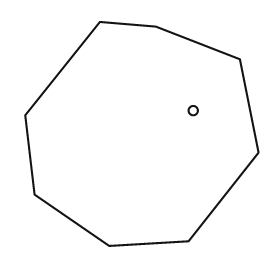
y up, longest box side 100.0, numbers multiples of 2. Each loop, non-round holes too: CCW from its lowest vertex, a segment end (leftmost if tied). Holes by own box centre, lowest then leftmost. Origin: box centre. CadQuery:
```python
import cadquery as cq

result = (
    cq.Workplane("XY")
    .moveTo(-14.0, -48.0)
    .lineTo(20.0, -46.0)
    .lineTo(50.0, -8.0)
    .lineTo(42.0, 32.0)
    .lineTo(6.0, 46.0)
    .lineTo(-18.0, 48.0)
    .lineTo(-50.0, 8.0)
    .lineTo(-46.0, -26.0)
    .close()
    .moveTo(22.0, 10.0)
    .circle(2.0)
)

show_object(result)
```